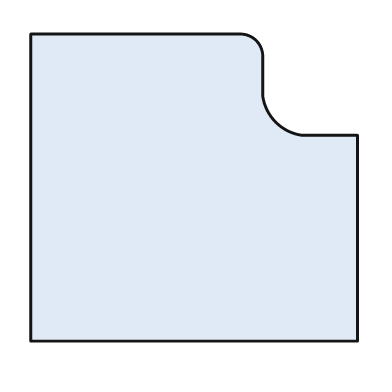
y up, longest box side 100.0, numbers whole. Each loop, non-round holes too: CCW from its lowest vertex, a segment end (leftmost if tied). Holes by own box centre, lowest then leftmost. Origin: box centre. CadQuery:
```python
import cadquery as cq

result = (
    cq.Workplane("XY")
    .moveTo(-50.0, -47.0)
    .lineTo(50.0, -47.0)
    .lineTo(50.0, 16.0)
    .lineTo(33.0, 16.0)
    .threePointArc((25.0, 20.0), (21.0, 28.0))
    .lineTo(21.0, 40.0)
    .threePointArc((19.0, 45.0), (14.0, 47.0))
    .lineTo(-50.0, 47.0)
    .close()
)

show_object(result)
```